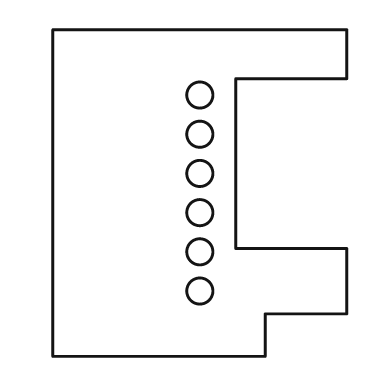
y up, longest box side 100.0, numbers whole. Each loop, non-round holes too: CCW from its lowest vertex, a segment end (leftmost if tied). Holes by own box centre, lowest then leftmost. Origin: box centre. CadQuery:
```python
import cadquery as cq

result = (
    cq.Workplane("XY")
    .moveTo(-45.0, -50.0)
    .lineTo(20.0, -50.0)
    .lineTo(20.0, -37.0)
    .lineTo(45.0, -37.0)
    .lineTo(45.0, -17.0)
    .lineTo(11.0, -17.0)
    .lineTo(11.0, 35.0)
    .lineTo(45.0, 35.0)
    .lineTo(45.0, 50.0)
    .lineTo(-45.0, 50.0)
    .close()
    .moveTo(0.0, -30.0)
    .circle(4.0)
    .moveTo(0.0, -18.0)
    .circle(4.0)
    .moveTo(0.0, -6.0)
    .circle(4.0)
    .moveTo(0.0, 6.0)
    .circle(4.0)
    .moveTo(0.0, 18.0)
    .circle(4.0)
    .moveTo(0.0, 30.0)
    .circle(4.0)
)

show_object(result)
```